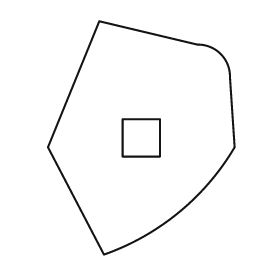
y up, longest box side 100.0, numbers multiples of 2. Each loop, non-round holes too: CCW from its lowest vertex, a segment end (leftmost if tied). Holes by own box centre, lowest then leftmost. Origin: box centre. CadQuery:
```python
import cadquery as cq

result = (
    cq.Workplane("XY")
    .moveTo(-16.0, -50.0)
    .threePointArc((16.0, -32.0), (40.0, -4.0))
    .lineTo(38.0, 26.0)
    .threePointArc((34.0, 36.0), (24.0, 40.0))
    .lineTo(-18.0, 50.0)
    .lineTo(-40.0, -4.0)
    .close()
    .moveTo(-8.0, -8.0)
    .lineTo(8.0, -8.0)
    .lineTo(8.0, 8.0)
    .lineTo(-8.0, 8.0)
    .close()
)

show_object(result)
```